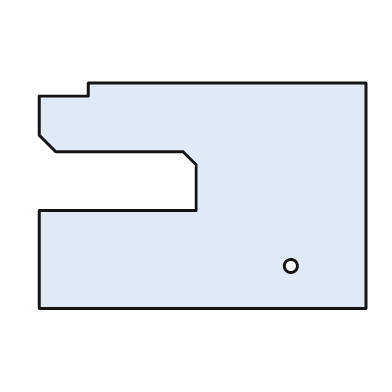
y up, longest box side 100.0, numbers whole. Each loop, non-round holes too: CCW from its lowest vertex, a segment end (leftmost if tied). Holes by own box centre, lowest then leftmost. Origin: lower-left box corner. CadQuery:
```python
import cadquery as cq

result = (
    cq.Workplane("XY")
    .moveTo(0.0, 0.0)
    .lineTo(100.0, 0.0)
    .lineTo(100.0, 69.0)
    .lineTo(15.0, 69.0)
    .lineTo(15.0, 65.0)
    .lineTo(0.0, 65.0)
    .lineTo(0.0, 53.0)
    .lineTo(5.0, 48.0)
    .lineTo(44.0, 48.0)
    .lineTo(48.0, 44.0)
    .lineTo(48.0, 30.0)
    .lineTo(0.0, 30.0)
    .close()
    .moveTo(77.0, 13.0)
    .circle(2.0)
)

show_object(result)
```